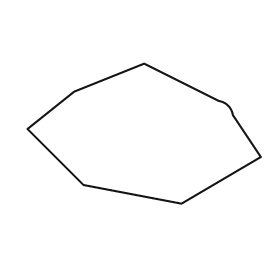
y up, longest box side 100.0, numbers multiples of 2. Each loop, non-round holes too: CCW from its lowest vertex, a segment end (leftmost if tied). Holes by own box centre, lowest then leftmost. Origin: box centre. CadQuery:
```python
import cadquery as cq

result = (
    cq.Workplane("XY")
    .moveTo(16.0, -30.0)
    .lineTo(50.0, -10.0)
    .lineTo(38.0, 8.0)
    .threePointArc((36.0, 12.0), (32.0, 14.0))
    .lineTo(0.0, 30.0)
    .lineTo(-30.0, 18.0)
    .lineTo(-50.0, 2.0)
    .lineTo(-26.0, -22.0)
    .close()
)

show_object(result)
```